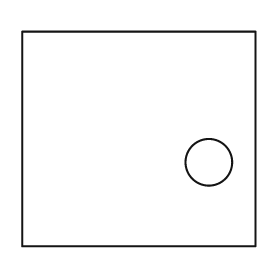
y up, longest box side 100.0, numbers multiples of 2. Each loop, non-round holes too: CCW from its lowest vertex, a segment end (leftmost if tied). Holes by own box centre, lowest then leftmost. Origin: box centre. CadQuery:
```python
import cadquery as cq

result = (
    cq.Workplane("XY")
    .moveTo(-50.0, -46.0)
    .lineTo(50.0, -46.0)
    .lineTo(50.0, 46.0)
    .lineTo(-50.0, 46.0)
    .close()
    .moveTo(30.0, -10.0)
    .circle(10.0)
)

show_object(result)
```